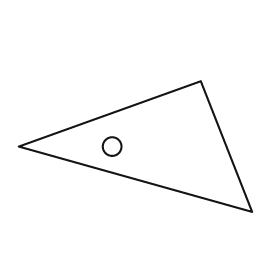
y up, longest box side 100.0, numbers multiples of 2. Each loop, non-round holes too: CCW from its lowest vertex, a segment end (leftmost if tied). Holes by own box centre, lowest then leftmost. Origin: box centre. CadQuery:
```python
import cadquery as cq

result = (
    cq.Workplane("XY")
    .moveTo(50.0, -28.0)
    .lineTo(28.0, 28.0)
    .lineTo(-50.0, 0.0)
    .close()
    .moveTo(-10.0, 0.0)
    .circle(4.0)
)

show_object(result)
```